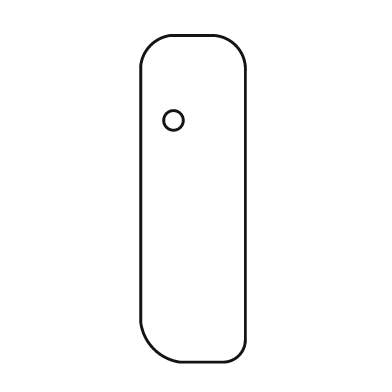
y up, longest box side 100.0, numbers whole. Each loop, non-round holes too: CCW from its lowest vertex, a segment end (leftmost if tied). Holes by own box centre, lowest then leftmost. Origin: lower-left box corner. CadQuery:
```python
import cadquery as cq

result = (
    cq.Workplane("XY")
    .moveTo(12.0, 0.0)
    .lineTo(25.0, 0.0)
    .threePointArc((30.0, 2.0), (32.0, 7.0))
    .lineTo(32.0, 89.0)
    .threePointArc((29.0, 97.0), (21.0, 100.0))
    .lineTo(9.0, 100.0)
    .threePointArc((3.0, 97.0), (0.0, 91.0))
    .lineTo(0.0, 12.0)
    .threePointArc((4.0, 4.0), (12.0, 0.0))
    .close()
    .moveTo(10.0, 74.0)
    .circle(3.0)
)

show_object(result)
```